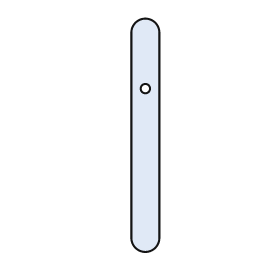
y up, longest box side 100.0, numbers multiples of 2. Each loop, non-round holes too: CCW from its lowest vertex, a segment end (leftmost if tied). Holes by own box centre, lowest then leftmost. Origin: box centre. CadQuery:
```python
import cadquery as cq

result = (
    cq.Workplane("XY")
    .moveTo(-6.0, -44.0)
    .threePointArc((0.0, -50.0), (6.0, -44.0))
    .lineTo(6.0, 44.0)
    .threePointArc((0.0, 50.0), (-6.0, 44.0))
    .close()
    .moveTo(0.0, 20.0)
    .circle(2.0)
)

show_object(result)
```